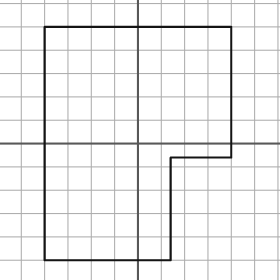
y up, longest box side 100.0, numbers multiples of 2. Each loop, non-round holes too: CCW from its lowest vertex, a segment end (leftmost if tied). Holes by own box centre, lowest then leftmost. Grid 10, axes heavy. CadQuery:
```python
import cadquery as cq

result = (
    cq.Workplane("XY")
    .moveTo(-40.0, -50.0)
    .lineTo(14.0, -50.0)
    .lineTo(14.0, -6.0)
    .lineTo(40.0, -6.0)
    .lineTo(40.0, 50.0)
    .lineTo(-40.0, 50.0)
    .close()
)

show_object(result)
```